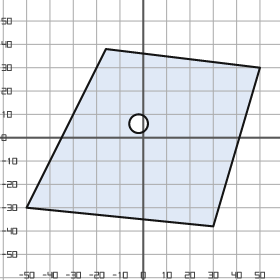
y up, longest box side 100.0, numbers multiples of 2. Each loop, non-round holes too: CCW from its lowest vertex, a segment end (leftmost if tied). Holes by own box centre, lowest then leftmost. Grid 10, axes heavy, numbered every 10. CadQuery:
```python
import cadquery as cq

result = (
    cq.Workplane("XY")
    .moveTo(30.0, -38.0)
    .lineTo(50.0, 30.0)
    .lineTo(-16.0, 38.0)
    .lineTo(-50.0, -30.0)
    .close()
    .moveTo(-2.0, 6.0)
    .circle(4.0)
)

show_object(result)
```